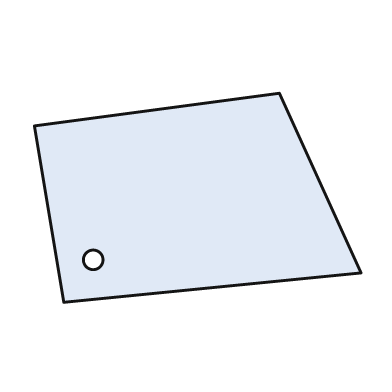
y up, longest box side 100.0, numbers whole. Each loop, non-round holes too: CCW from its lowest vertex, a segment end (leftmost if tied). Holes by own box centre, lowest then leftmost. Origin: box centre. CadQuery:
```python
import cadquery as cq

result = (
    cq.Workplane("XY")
    .moveTo(-41.0, -32.0)
    .lineTo(50.0, -23.0)
    .lineTo(25.0, 32.0)
    .lineTo(-50.0, 22.0)
    .close()
    .moveTo(-32.0, -19.0)
    .circle(3.0)
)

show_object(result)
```